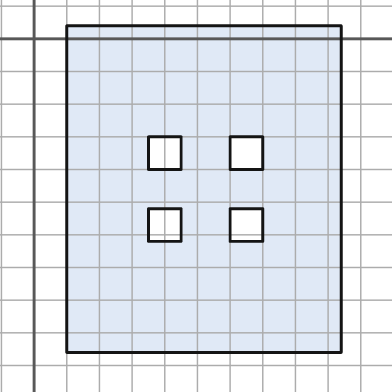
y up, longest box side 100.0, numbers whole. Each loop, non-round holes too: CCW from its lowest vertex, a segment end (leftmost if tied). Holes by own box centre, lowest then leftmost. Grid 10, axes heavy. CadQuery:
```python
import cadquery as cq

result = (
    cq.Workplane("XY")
    .moveTo(10.0, -96.0)
    .lineTo(94.0, -96.0)
    .lineTo(94.0, 4.0)
    .lineTo(10.0, 4.0)
    .close()
    .moveTo(35.0, -62.0)
    .lineTo(45.0, -62.0)
    .lineTo(45.0, -52.0)
    .lineTo(35.0, -52.0)
    .close()
    .moveTo(60.0, -62.0)
    .lineTo(70.0, -62.0)
    .lineTo(70.0, -52.0)
    .lineTo(60.0, -52.0)
    .close()
    .moveTo(35.0, -40.0)
    .lineTo(45.0, -40.0)
    .lineTo(45.0, -30.0)
    .lineTo(35.0, -30.0)
    .close()
    .moveTo(60.0, -40.0)
    .lineTo(70.0, -40.0)
    .lineTo(70.0, -30.0)
    .lineTo(60.0, -30.0)
    .close()
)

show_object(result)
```